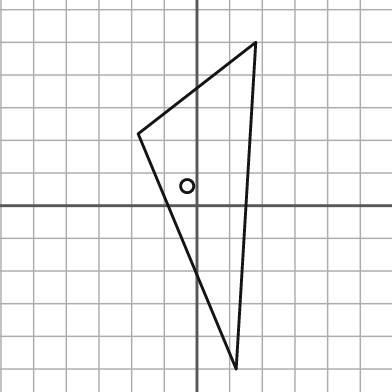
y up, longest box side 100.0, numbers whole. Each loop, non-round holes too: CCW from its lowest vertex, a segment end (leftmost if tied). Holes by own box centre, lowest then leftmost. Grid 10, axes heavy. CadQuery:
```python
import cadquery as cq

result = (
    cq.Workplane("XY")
    .moveTo(12.0, -50.0)
    .lineTo(18.0, 50.0)
    .lineTo(-18.0, 22.0)
    .close()
    .moveTo(-3.0, 6.0)
    .circle(2.0)
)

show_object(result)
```